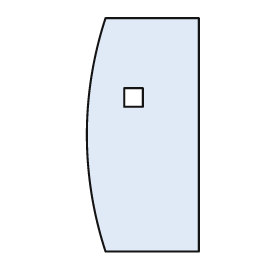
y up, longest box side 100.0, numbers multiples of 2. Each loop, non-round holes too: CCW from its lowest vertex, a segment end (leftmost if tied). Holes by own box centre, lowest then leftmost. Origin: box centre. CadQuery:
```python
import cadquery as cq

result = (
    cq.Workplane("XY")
    .moveTo(-16.0, -50.0)
    .lineTo(24.0, -50.0)
    .lineTo(24.0, 50.0)
    .lineTo(-16.0, 50.0)
    .threePointArc((-24.0, 0.0), (-16.0, -50.0))
    .close()
    .moveTo(-8.0, 12.0)
    .lineTo(0.0, 12.0)
    .lineTo(0.0, 20.0)
    .lineTo(-8.0, 20.0)
    .close()
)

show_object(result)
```